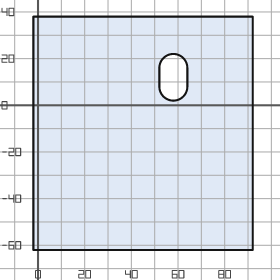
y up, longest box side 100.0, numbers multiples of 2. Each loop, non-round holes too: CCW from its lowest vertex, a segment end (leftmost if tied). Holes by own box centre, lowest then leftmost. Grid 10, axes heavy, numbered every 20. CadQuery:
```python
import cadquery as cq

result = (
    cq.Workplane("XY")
    .moveTo(-2.0, -62.0)
    .lineTo(92.0, -62.0)
    .lineTo(92.0, 38.0)
    .lineTo(-2.0, 38.0)
    .close()
    .moveTo(52.0, 8.0)
    .threePointArc((58.0, 2.0), (64.0, 8.0))
    .lineTo(64.0, 16.0)
    .threePointArc((58.0, 22.0), (52.0, 16.0))
    .close()
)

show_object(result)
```